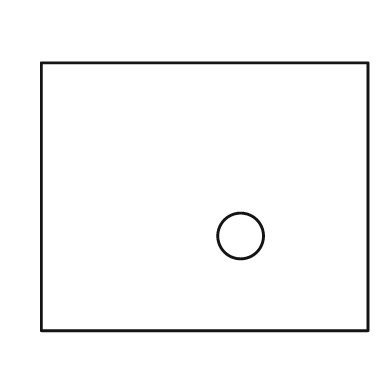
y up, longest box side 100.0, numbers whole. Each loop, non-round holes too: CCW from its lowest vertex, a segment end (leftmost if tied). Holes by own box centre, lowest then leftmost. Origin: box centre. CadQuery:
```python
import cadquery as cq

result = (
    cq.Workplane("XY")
    .moveTo(-50.0, -41.0)
    .lineTo(50.0, -41.0)
    .lineTo(50.0, 41.0)
    .lineTo(-50.0, 41.0)
    .close()
    .moveTo(11.0, -12.0)
    .circle(7.0)
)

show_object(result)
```